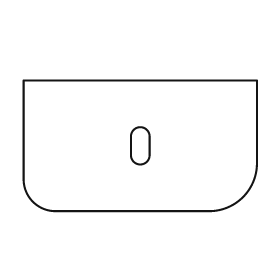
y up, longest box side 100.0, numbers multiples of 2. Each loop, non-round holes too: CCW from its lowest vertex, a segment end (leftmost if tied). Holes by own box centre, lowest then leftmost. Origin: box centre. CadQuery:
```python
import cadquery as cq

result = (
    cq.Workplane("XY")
    .moveTo(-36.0, -28.0)
    .lineTo(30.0, -28.0)
    .threePointArc((44.0, -22.0), (50.0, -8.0))
    .lineTo(50.0, 28.0)
    .lineTo(-50.0, 28.0)
    .lineTo(-50.0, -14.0)
    .threePointArc((-46.0, -24.0), (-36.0, -28.0))
    .close()
    .moveTo(-4.0, -4.0)
    .threePointArc((0.0, -8.0), (4.0, -4.0))
    .lineTo(4.0, 4.0)
    .threePointArc((0.0, 8.0), (-4.0, 4.0))
    .close()
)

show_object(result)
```